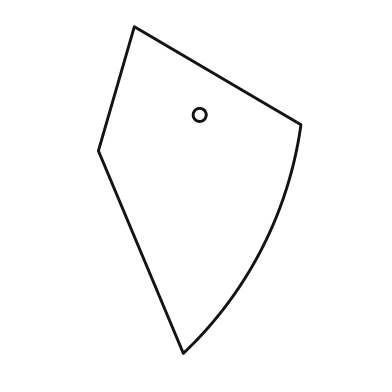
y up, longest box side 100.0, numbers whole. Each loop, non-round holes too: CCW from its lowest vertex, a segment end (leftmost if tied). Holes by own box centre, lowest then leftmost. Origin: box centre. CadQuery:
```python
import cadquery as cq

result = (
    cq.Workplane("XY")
    .moveTo(-5.0, -50.0)
    .threePointArc((19.0, -18.0), (31.0, 20.0))
    .lineTo(-20.0, 50.0)
    .lineTo(-31.0, 12.0)
    .close()
    .moveTo(0.0, 23.0)
    .circle(2.0)
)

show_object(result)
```